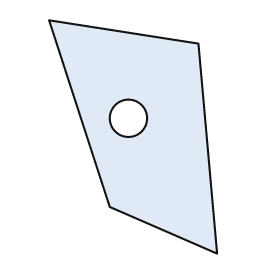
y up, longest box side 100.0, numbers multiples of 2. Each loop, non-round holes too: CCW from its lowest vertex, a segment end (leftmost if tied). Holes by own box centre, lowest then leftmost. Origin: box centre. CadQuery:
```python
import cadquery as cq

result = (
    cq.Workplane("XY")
    .moveTo(36.0, -50.0)
    .lineTo(28.0, 40.0)
    .lineTo(-36.0, 50.0)
    .lineTo(-10.0, -30.0)
    .close()
    .moveTo(-2.0, 8.0)
    .circle(8.0)
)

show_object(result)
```